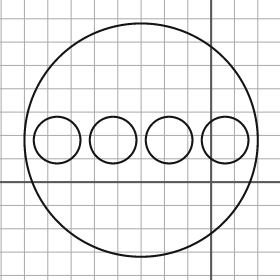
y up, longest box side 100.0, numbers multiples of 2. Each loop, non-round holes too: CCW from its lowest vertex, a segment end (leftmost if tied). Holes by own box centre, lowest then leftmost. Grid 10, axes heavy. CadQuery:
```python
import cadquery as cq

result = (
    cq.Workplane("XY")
    .moveTo(-30.0, 18.0)
    .circle(50.0)
    .moveTo(-66.0, 18.0)
    .circle(10.0)
    .moveTo(-42.0, 18.0)
    .circle(10.0)
    .moveTo(-18.0, 18.0)
    .circle(10.0)
    .moveTo(6.0, 18.0)
    .circle(10.0)
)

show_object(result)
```